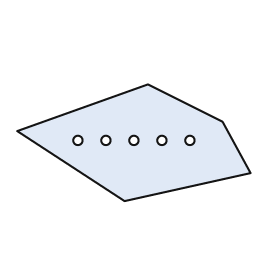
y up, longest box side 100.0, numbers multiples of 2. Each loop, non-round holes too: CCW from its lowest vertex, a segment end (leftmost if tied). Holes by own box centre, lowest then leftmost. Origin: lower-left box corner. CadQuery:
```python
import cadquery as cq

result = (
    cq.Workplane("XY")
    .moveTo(46.0, 0.0)
    .lineTo(100.0, 12.0)
    .lineTo(88.0, 34.0)
    .lineTo(56.0, 50.0)
    .lineTo(0.0, 30.0)
    .close()
    .moveTo(26.0, 26.0)
    .circle(2.0)
    .moveTo(38.0, 26.0)
    .circle(2.0)
    .moveTo(50.0, 26.0)
    .circle(2.0)
    .moveTo(62.0, 26.0)
    .circle(2.0)
    .moveTo(74.0, 26.0)
    .circle(2.0)
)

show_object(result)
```